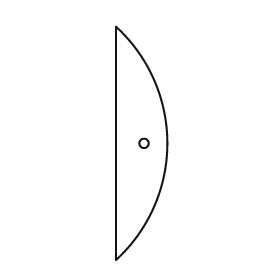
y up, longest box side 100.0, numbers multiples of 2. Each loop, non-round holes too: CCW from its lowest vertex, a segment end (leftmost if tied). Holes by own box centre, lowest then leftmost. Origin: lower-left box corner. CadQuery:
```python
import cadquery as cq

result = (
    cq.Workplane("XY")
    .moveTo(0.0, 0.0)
    .threePointArc((22.0, 50.0), (0.0, 100.0))
    .close()
    .moveTo(12.0, 50.0)
    .circle(2.0)
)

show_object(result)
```